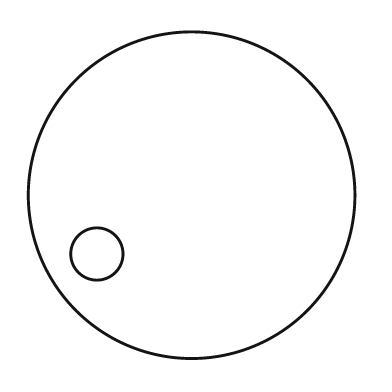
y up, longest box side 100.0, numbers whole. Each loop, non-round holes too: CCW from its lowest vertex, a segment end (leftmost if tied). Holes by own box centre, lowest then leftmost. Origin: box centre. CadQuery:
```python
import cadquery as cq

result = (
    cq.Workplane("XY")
    .moveTo(0.0, 0.0)
    .circle(50.0)
    .moveTo(-29.0, -18.0)
    .circle(8.0)
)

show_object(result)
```